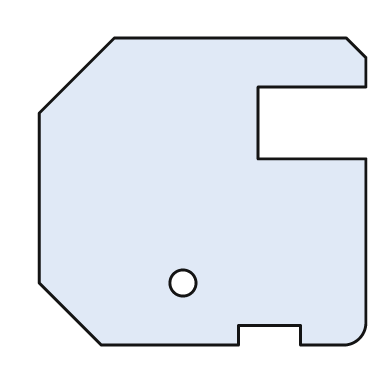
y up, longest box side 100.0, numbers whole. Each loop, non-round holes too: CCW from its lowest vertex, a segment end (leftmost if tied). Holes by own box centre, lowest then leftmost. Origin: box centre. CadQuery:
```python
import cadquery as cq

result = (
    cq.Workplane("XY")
    .moveTo(-31.0, -47.0)
    .lineTo(11.0, -47.0)
    .lineTo(11.0, -41.0)
    .lineTo(30.0, -41.0)
    .lineTo(30.0, -47.0)
    .lineTo(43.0, -47.0)
    .threePointArc((48.0, -45.0), (50.0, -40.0))
    .lineTo(50.0, 10.0)
    .lineTo(17.0, 10.0)
    .lineTo(17.0, 32.0)
    .lineTo(50.0, 32.0)
    .lineTo(50.0, 41.0)
    .lineTo(44.0, 47.0)
    .lineTo(-27.0, 47.0)
    .lineTo(-50.0, 24.0)
    .lineTo(-50.0, -28.0)
    .close()
    .moveTo(-6.0, -28.0)
    .circle(4.0)
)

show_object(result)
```